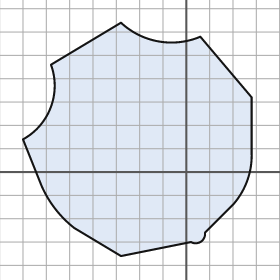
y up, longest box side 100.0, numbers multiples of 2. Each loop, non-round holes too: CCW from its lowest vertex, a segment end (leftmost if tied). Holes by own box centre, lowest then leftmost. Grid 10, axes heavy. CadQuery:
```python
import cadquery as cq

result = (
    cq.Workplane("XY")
    .moveTo(-28.0, -36.0)
    .lineTo(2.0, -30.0)
    .threePointArc((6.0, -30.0), (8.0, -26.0))
    .lineTo(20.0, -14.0)
    .threePointArc((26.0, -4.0), (28.0, 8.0))
    .lineTo(28.0, 32.0)
    .lineTo(6.0, 58.0)
    .threePointArc((-12.0, 56.0), (-28.0, 64.0))
    .lineTo(-58.0, 46.0)
    .threePointArc((-58.0, 28.0), (-70.0, 14.0))
    .lineTo(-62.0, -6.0)
    .threePointArc((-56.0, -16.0), (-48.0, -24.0))
    .close()
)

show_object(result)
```